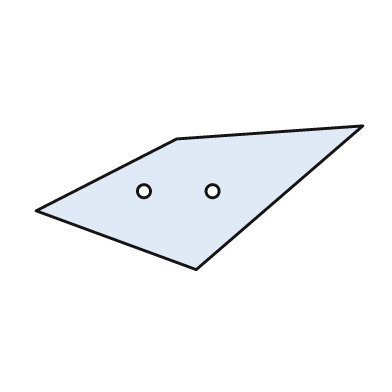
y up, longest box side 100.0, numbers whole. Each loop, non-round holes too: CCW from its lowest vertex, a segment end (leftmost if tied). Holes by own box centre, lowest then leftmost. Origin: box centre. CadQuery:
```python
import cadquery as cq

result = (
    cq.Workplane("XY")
    .moveTo(-1.0, -22.0)
    .lineTo(50.0, 22.0)
    .lineTo(-7.0, 18.0)
    .lineTo(-50.0, -4.0)
    .close()
    .moveTo(-17.0, 2.0)
    .circle(2.0)
    .moveTo(4.0, 2.0)
    .circle(2.0)
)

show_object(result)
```